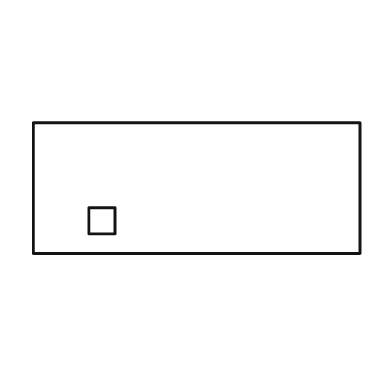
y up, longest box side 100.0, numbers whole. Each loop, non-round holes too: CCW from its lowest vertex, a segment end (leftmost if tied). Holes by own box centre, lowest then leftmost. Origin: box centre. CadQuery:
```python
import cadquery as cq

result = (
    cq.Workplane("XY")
    .moveTo(-50.0, -20.0)
    .lineTo(50.0, -20.0)
    .lineTo(50.0, 20.0)
    .lineTo(-50.0, 20.0)
    .close()
    .moveTo(-33.0, -14.0)
    .lineTo(-25.0, -14.0)
    .lineTo(-25.0, -6.0)
    .lineTo(-33.0, -6.0)
    .close()
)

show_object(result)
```